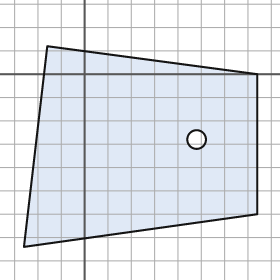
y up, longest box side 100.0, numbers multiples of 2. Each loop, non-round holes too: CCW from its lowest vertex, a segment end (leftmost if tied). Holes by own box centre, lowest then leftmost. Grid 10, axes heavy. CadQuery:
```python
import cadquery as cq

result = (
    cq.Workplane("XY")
    .moveTo(-26.0, -74.0)
    .lineTo(74.0, -60.0)
    .lineTo(74.0, 0.0)
    .lineTo(-16.0, 12.0)
    .close()
    .moveTo(48.0, -28.0)
    .circle(4.0)
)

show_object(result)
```